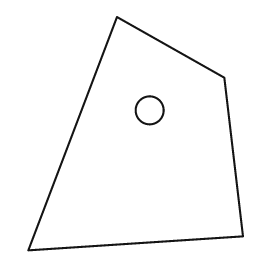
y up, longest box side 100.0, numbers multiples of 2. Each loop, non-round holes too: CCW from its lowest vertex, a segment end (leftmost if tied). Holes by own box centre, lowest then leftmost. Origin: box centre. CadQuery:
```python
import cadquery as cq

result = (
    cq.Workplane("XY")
    .moveTo(-46.0, -50.0)
    .lineTo(46.0, -44.0)
    .lineTo(38.0, 24.0)
    .lineTo(-8.0, 50.0)
    .close()
    .moveTo(6.0, 10.0)
    .circle(6.0)
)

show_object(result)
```